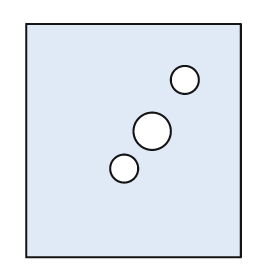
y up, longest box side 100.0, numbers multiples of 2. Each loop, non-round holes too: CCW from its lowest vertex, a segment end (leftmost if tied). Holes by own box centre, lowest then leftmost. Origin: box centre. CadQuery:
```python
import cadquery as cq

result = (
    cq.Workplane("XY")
    .moveTo(-46.0, -50.0)
    .lineTo(46.0, -50.0)
    .lineTo(46.0, 50.0)
    .lineTo(-46.0, 50.0)
    .close()
    .moveTo(-4.0, -12.0)
    .circle(6.0)
    .moveTo(8.0, 4.0)
    .circle(8.0)
    .moveTo(22.0, 26.0)
    .circle(6.0)
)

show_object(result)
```